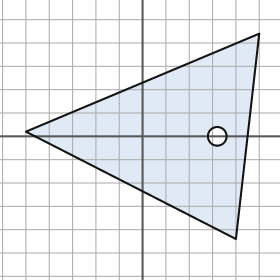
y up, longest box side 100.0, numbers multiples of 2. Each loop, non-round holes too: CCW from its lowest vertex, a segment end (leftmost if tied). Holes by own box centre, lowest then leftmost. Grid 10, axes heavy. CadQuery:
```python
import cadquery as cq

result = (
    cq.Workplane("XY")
    .moveTo(40.0, -44.0)
    .lineTo(50.0, 44.0)
    .lineTo(-50.0, 2.0)
    .close()
    .moveTo(32.0, 0.0)
    .circle(4.0)
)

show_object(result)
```